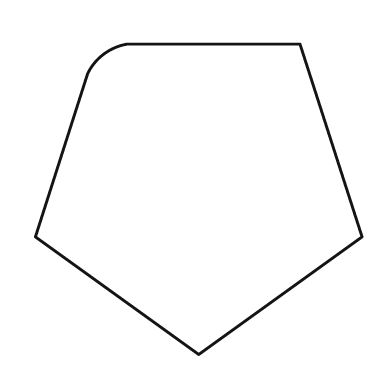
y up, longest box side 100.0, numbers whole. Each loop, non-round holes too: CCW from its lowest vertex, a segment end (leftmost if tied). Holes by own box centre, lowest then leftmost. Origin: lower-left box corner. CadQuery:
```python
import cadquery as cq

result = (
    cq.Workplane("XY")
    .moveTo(50.0, 0.0)
    .lineTo(100.0, 36.0)
    .lineTo(81.0, 95.0)
    .lineTo(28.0, 95.0)
    .threePointArc((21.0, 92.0), (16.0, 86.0))
    .lineTo(0.0, 36.0)
    .close()
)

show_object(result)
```